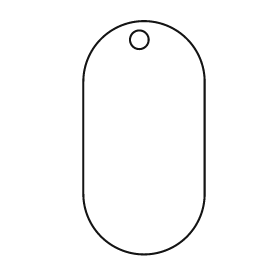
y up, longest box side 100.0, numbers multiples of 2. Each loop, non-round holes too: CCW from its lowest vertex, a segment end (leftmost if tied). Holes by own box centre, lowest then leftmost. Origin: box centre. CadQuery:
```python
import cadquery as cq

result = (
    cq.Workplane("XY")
    .moveTo(-26.0, -24.0)
    .threePointArc((0.0, -50.0), (26.0, -24.0))
    .lineTo(26.0, 24.0)
    .threePointArc((0.0, 50.0), (-26.0, 24.0))
    .close()
    .moveTo(-2.0, 42.0)
    .circle(4.0)
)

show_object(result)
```